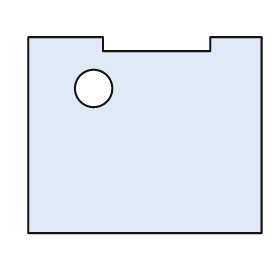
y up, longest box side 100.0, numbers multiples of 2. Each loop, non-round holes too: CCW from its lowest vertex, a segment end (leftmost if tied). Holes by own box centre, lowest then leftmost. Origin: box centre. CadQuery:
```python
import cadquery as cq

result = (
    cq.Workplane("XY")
    .moveTo(-50.0, -42.0)
    .lineTo(50.0, -42.0)
    .lineTo(50.0, 42.0)
    .lineTo(28.0, 42.0)
    .lineTo(28.0, 36.0)
    .lineTo(-18.0, 36.0)
    .lineTo(-18.0, 42.0)
    .lineTo(-50.0, 42.0)
    .close()
    .moveTo(-22.0, 20.0)
    .circle(8.0)
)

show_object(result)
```